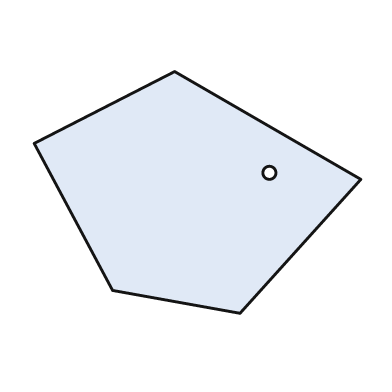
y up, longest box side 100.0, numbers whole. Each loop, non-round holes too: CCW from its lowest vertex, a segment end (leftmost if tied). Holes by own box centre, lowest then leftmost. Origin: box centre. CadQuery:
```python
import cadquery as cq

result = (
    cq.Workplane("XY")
    .moveTo(13.0, -37.0)
    .lineTo(50.0, 4.0)
    .lineTo(-7.0, 37.0)
    .lineTo(-50.0, 15.0)
    .lineTo(-26.0, -30.0)
    .close()
    .moveTo(22.0, 6.0)
    .circle(2.0)
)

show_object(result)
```